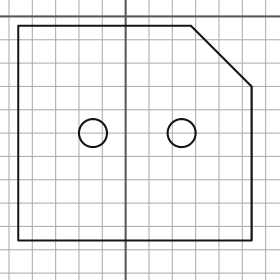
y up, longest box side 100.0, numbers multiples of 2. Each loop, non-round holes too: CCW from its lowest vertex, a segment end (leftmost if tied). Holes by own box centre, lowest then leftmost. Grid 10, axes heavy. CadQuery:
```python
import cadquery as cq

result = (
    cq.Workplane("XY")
    .moveTo(-46.0, -96.0)
    .lineTo(54.0, -96.0)
    .lineTo(54.0, -30.0)
    .lineTo(28.0, -4.0)
    .lineTo(-46.0, -4.0)
    .close()
    .moveTo(-14.0, -50.0)
    .circle(6.0)
    .moveTo(24.0, -50.0)
    .circle(6.0)
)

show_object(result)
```